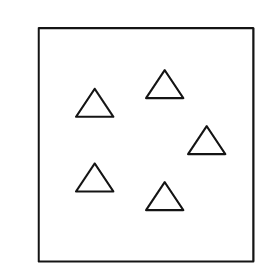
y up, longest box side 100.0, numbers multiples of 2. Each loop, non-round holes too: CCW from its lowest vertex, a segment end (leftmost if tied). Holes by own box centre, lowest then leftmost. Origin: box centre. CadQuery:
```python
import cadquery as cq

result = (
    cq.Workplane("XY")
    .moveTo(-46.0, -50.0)
    .lineTo(46.0, -50.0)
    .lineTo(46.0, 50.0)
    .lineTo(-46.0, 50.0)
    .close()
    .moveTo(0.0, -28.0)
    .lineTo(16.0, -28.0)
    .lineTo(8.0, -16.0)
    .close()
    .moveTo(-30.0, -20.0)
    .lineTo(-14.0, -20.0)
    .lineTo(-22.0, -8.0)
    .close()
    .moveTo(18.0, -4.0)
    .lineTo(34.0, -4.0)
    .lineTo(26.0, 8.0)
    .close()
    .moveTo(-30.0, 12.0)
    .lineTo(-14.0, 12.0)
    .lineTo(-22.0, 24.0)
    .close()
    .moveTo(0.0, 20.0)
    .lineTo(16.0, 20.0)
    .lineTo(8.0, 32.0)
    .close()
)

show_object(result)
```